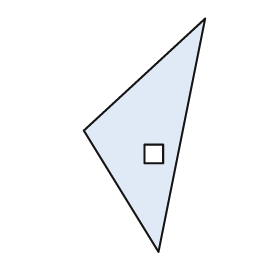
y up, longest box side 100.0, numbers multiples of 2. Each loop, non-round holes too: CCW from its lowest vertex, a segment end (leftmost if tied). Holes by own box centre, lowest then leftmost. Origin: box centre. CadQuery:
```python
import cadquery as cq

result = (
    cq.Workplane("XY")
    .moveTo(6.0, -50.0)
    .lineTo(26.0, 50.0)
    .lineTo(-26.0, 2.0)
    .close()
    .moveTo(0.0, -12.0)
    .lineTo(8.0, -12.0)
    .lineTo(8.0, -4.0)
    .lineTo(0.0, -4.0)
    .close()
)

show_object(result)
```